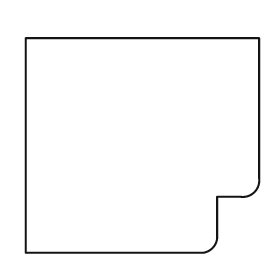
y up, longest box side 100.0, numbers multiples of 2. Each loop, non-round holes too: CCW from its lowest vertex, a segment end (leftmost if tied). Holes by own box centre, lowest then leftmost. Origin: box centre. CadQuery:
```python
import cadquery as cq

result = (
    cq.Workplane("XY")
    .moveTo(-50.0, -46.0)
    .lineTo(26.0, -46.0)
    .threePointArc((30.0, -44.0), (32.0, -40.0))
    .lineTo(32.0, -22.0)
    .lineTo(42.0, -22.0)
    .threePointArc((48.0, -20.0), (50.0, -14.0))
    .lineTo(50.0, 46.0)
    .lineTo(-50.0, 46.0)
    .close()
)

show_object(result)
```